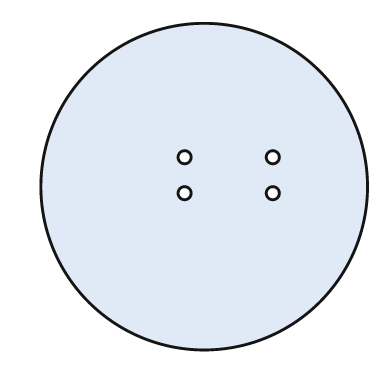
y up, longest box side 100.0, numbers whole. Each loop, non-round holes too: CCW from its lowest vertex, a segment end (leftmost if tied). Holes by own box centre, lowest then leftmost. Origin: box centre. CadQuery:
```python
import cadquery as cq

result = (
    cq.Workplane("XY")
    .moveTo(0.0, 0.0)
    .circle(50.0)
    .moveTo(-6.0, -2.0)
    .circle(2.0)
    .moveTo(21.0, -2.0)
    .circle(2.0)
    .moveTo(-6.0, 9.0)
    .circle(2.0)
    .moveTo(21.0, 9.0)
    .circle(2.0)
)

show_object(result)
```